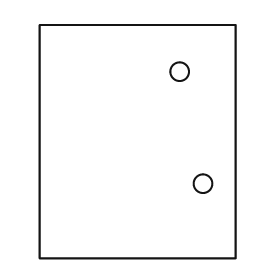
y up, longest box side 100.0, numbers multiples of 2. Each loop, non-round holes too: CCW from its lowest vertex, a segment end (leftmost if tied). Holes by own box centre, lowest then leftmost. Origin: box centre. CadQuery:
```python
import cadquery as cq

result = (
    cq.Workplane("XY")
    .moveTo(-42.0, -50.0)
    .lineTo(42.0, -50.0)
    .lineTo(42.0, 50.0)
    .lineTo(-42.0, 50.0)
    .close()
    .moveTo(28.0, -18.0)
    .circle(4.0)
    .moveTo(18.0, 30.0)
    .circle(4.0)
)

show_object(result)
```